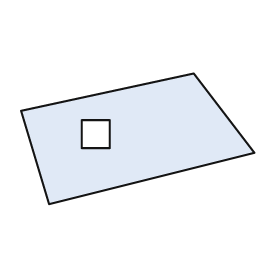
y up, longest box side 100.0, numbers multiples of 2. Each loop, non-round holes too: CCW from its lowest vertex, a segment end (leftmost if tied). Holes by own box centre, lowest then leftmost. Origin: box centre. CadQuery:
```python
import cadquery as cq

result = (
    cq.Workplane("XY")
    .moveTo(-38.0, -28.0)
    .lineTo(50.0, -6.0)
    .lineTo(24.0, 28.0)
    .lineTo(-50.0, 12.0)
    .close()
    .moveTo(-24.0, -4.0)
    .lineTo(-12.0, -4.0)
    .lineTo(-12.0, 8.0)
    .lineTo(-24.0, 8.0)
    .close()
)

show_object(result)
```